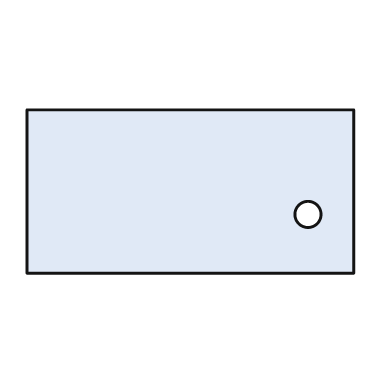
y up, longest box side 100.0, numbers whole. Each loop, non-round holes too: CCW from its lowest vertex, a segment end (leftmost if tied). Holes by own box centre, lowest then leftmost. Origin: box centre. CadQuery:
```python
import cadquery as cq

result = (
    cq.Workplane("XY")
    .moveTo(-50.0, -25.0)
    .lineTo(50.0, -25.0)
    .lineTo(50.0, 25.0)
    .lineTo(-50.0, 25.0)
    .close()
    .moveTo(36.0, -7.0)
    .circle(4.0)
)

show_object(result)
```